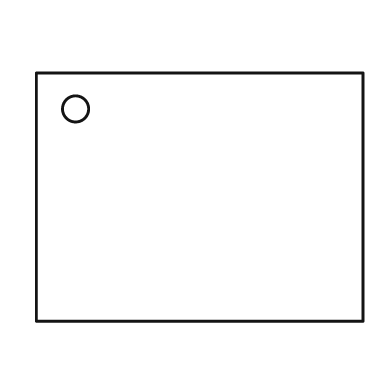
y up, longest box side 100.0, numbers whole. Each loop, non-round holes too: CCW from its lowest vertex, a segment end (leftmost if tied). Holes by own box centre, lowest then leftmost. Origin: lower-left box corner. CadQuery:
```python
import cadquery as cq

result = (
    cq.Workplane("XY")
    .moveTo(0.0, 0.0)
    .lineTo(100.0, 0.0)
    .lineTo(100.0, 76.0)
    .lineTo(0.0, 76.0)
    .close()
    .moveTo(12.0, 65.0)
    .circle(4.0)
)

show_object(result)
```